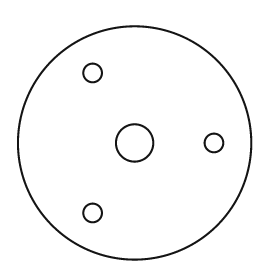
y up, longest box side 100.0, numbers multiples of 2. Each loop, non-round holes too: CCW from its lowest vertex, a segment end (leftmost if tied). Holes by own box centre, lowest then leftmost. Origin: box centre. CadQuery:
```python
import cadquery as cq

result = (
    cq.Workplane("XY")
    .moveTo(0.0, 0.0)
    .circle(50.0)
    .moveTo(-18.0, -30.0)
    .circle(4.0)
    .moveTo(0.0, 0.0)
    .circle(8.0)
    .moveTo(34.0, 0.0)
    .circle(4.0)
    .moveTo(-18.0, 30.0)
    .circle(4.0)
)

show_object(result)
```